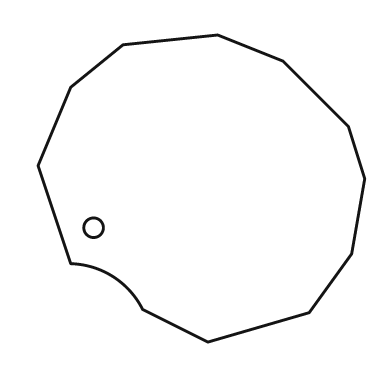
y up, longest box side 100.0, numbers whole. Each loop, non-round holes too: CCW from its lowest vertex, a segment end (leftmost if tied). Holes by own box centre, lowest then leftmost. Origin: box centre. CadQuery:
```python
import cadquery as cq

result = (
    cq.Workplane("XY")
    .moveTo(2.0, -47.0)
    .lineTo(33.0, -38.0)
    .lineTo(46.0, -20.0)
    .lineTo(50.0, 3.0)
    .lineTo(45.0, 19.0)
    .lineTo(25.0, 39.0)
    .lineTo(5.0, 47.0)
    .lineTo(-24.0, 44.0)
    .lineTo(-40.0, 31.0)
    .lineTo(-50.0, 7.0)
    .lineTo(-40.0, -23.0)
    .threePointArc((-27.0, -27.0), (-18.0, -37.0))
    .close()
    .moveTo(-33.0, -12.0)
    .circle(3.0)
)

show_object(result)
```